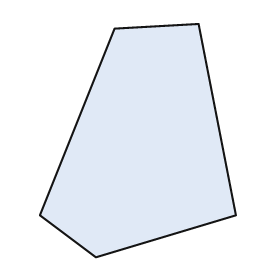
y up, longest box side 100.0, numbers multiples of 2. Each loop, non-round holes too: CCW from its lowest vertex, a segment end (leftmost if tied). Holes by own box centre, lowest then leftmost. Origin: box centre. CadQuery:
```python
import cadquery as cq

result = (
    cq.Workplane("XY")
    .moveTo(-18.0, -50.0)
    .lineTo(42.0, -32.0)
    .lineTo(26.0, 50.0)
    .lineTo(-10.0, 48.0)
    .lineTo(-42.0, -32.0)
    .close()
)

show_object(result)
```